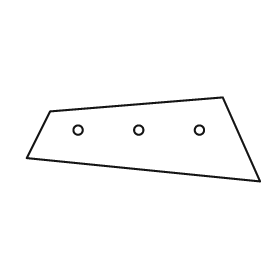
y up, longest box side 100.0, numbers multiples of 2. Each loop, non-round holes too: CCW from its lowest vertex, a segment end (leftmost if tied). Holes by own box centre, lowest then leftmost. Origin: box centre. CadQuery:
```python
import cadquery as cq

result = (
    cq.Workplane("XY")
    .moveTo(50.0, -18.0)
    .lineTo(34.0, 18.0)
    .lineTo(-40.0, 12.0)
    .lineTo(-50.0, -8.0)
    .close()
    .moveTo(-28.0, 4.0)
    .circle(2.0)
    .moveTo(-2.0, 4.0)
    .circle(2.0)
    .moveTo(24.0, 4.0)
    .circle(2.0)
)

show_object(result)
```